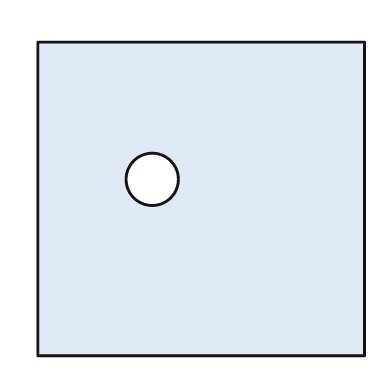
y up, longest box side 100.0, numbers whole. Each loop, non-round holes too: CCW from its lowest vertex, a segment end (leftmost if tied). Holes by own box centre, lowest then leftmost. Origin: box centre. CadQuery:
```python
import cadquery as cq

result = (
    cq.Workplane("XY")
    .moveTo(-50.0, -48.0)
    .lineTo(50.0, -48.0)
    .lineTo(50.0, 48.0)
    .lineTo(-50.0, 48.0)
    .close()
    .moveTo(-15.0, 6.0)
    .circle(8.0)
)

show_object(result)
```